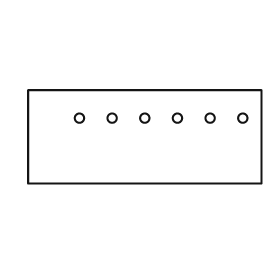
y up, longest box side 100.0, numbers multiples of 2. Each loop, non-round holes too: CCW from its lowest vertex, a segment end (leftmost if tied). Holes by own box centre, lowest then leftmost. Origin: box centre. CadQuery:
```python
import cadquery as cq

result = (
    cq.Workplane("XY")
    .moveTo(-50.0, -20.0)
    .lineTo(50.0, -20.0)
    .lineTo(50.0, 20.0)
    .lineTo(-50.0, 20.0)
    .close()
    .moveTo(-28.0, 8.0)
    .circle(2.0)
    .moveTo(-14.0, 8.0)
    .circle(2.0)
    .moveTo(0.0, 8.0)
    .circle(2.0)
    .moveTo(14.0, 8.0)
    .circle(2.0)
    .moveTo(28.0, 8.0)
    .circle(2.0)
    .moveTo(42.0, 8.0)
    .circle(2.0)
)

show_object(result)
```